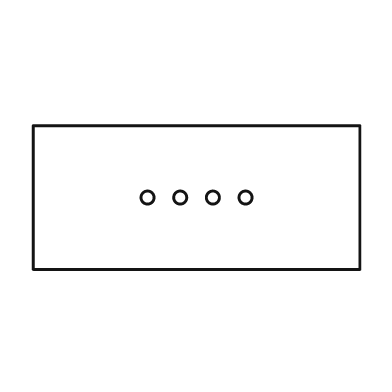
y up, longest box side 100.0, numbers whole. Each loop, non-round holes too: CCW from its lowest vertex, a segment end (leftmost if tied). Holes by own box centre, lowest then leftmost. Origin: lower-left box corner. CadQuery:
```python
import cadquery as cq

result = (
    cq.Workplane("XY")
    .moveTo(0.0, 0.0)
    .lineTo(100.0, 0.0)
    .lineTo(100.0, 44.0)
    .lineTo(0.0, 44.0)
    .close()
    .moveTo(35.0, 22.0)
    .circle(2.0)
    .moveTo(45.0, 22.0)
    .circle(2.0)
    .moveTo(55.0, 22.0)
    .circle(2.0)
    .moveTo(65.0, 22.0)
    .circle(2.0)
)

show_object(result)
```